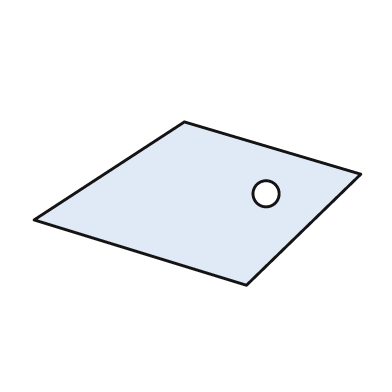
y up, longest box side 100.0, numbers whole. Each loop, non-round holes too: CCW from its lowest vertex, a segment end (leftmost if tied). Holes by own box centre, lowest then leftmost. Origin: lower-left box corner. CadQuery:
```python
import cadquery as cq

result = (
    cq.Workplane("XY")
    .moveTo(65.0, 0.0)
    .lineTo(100.0, 34.0)
    .lineTo(46.0, 50.0)
    .lineTo(0.0, 20.0)
    .close()
    .moveTo(71.0, 28.0)
    .circle(4.0)
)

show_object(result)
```